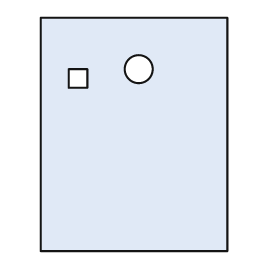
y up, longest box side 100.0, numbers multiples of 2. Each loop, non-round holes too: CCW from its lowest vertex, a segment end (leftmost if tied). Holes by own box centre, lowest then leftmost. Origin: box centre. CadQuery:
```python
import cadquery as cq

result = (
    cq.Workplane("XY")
    .moveTo(-40.0, -50.0)
    .lineTo(40.0, -50.0)
    .lineTo(40.0, 50.0)
    .lineTo(-40.0, 50.0)
    .close()
    .moveTo(-28.0, 20.0)
    .lineTo(-20.0, 20.0)
    .lineTo(-20.0, 28.0)
    .lineTo(-28.0, 28.0)
    .close()
    .moveTo(2.0, 28.0)
    .circle(6.0)
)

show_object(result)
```